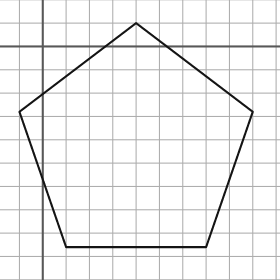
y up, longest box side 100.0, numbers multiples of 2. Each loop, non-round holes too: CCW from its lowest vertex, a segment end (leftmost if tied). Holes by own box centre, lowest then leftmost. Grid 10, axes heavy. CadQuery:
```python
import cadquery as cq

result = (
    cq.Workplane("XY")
    .moveTo(10.0, -86.0)
    .lineTo(70.0, -86.0)
    .lineTo(90.0, -28.0)
    .lineTo(40.0, 10.0)
    .lineTo(-10.0, -28.0)
    .close()
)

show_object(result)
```